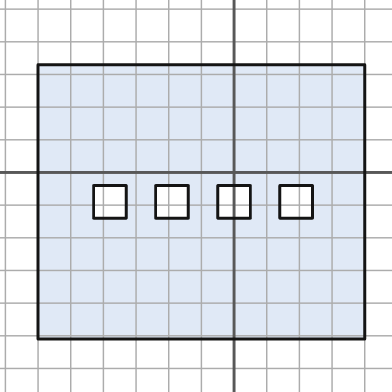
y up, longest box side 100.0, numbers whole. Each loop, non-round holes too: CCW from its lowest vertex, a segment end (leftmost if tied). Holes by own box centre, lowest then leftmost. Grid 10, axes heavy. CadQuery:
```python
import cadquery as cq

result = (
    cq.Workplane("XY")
    .moveTo(-60.0, -51.0)
    .lineTo(40.0, -51.0)
    .lineTo(40.0, 33.0)
    .lineTo(-60.0, 33.0)
    .close()
    .moveTo(-43.0, -14.0)
    .lineTo(-33.0, -14.0)
    .lineTo(-33.0, -4.0)
    .lineTo(-43.0, -4.0)
    .close()
    .moveTo(-24.0, -14.0)
    .lineTo(-14.0, -14.0)
    .lineTo(-14.0, -4.0)
    .lineTo(-24.0, -4.0)
    .close()
    .moveTo(-5.0, -14.0)
    .lineTo(5.0, -14.0)
    .lineTo(5.0, -4.0)
    .lineTo(-5.0, -4.0)
    .close()
    .moveTo(14.0, -14.0)
    .lineTo(24.0, -14.0)
    .lineTo(24.0, -4.0)
    .lineTo(14.0, -4.0)
    .close()
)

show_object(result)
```